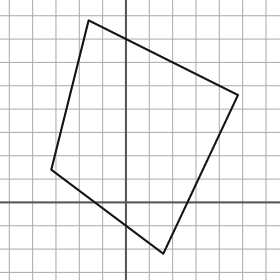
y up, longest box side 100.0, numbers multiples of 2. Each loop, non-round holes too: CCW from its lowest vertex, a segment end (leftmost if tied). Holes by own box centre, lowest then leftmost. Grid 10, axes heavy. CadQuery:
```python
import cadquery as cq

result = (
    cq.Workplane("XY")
    .moveTo(16.0, -22.0)
    .lineTo(48.0, 46.0)
    .lineTo(-16.0, 78.0)
    .lineTo(-32.0, 14.0)
    .close()
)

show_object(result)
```